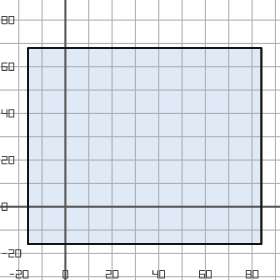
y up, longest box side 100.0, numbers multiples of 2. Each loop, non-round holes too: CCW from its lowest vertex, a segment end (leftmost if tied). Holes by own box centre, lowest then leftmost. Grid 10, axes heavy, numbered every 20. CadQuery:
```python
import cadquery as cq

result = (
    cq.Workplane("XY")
    .moveTo(-16.0, -16.0)
    .lineTo(84.0, -16.0)
    .lineTo(84.0, 68.0)
    .lineTo(-16.0, 68.0)
    .close()
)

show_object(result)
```